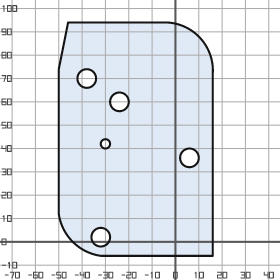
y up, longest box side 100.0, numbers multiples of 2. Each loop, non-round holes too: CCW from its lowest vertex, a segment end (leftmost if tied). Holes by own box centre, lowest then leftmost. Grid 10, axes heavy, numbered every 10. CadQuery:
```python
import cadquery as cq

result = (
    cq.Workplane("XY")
    .moveTo(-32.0, -6.0)
    .lineTo(16.0, -6.0)
    .lineTo(16.0, 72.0)
    .threePointArc((10.0, 88.0), (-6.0, 94.0))
    .lineTo(-46.0, 94.0)
    .lineTo(-50.0, 74.0)
    .lineTo(-50.0, 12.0)
    .threePointArc((-44.0, 0.0), (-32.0, -6.0))
    .close()
    .moveTo(-32.0, 2.0)
    .circle(4.0)
    .moveTo(6.0, 36.0)
    .circle(4.0)
    .moveTo(-30.0, 42.0)
    .circle(2.0)
    .moveTo(-24.0, 60.0)
    .circle(4.0)
    .moveTo(-38.0, 70.0)
    .circle(4.0)
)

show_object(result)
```